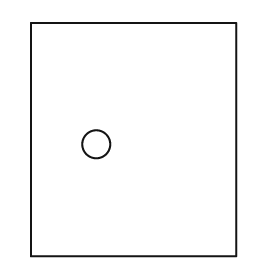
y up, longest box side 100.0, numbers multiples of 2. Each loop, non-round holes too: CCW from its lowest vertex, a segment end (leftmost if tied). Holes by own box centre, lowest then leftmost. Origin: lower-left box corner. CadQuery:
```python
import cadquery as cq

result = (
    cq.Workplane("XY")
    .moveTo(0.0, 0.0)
    .lineTo(88.0, 0.0)
    .lineTo(88.0, 100.0)
    .lineTo(0.0, 100.0)
    .close()
    .moveTo(28.0, 48.0)
    .circle(6.0)
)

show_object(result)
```